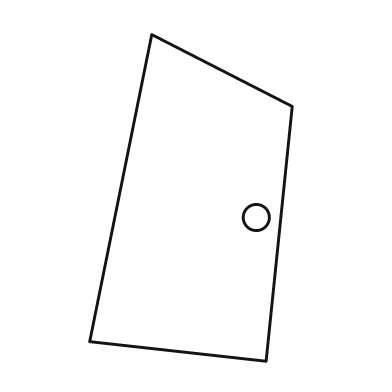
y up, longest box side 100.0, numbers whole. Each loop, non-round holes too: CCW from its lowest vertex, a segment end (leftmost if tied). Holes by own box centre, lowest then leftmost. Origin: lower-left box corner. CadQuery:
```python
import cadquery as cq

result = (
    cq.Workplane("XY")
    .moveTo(54.0, 0.0)
    .lineTo(62.0, 78.0)
    .lineTo(19.0, 100.0)
    .lineTo(0.0, 6.0)
    .close()
    .moveTo(51.0, 44.0)
    .circle(4.0)
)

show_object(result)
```